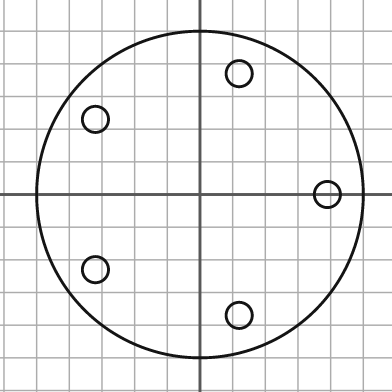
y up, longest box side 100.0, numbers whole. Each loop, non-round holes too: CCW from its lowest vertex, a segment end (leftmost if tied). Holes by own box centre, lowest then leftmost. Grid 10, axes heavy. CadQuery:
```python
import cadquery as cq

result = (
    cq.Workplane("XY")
    .moveTo(0.0, 0.0)
    .circle(50.0)
    .moveTo(12.0, -37.0)
    .circle(4.0)
    .moveTo(-32.0, -23.0)
    .circle(4.0)
    .moveTo(39.0, 0.0)
    .circle(4.0)
    .moveTo(-32.0, 23.0)
    .circle(4.0)
    .moveTo(12.0, 37.0)
    .circle(4.0)
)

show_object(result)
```